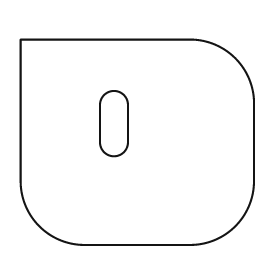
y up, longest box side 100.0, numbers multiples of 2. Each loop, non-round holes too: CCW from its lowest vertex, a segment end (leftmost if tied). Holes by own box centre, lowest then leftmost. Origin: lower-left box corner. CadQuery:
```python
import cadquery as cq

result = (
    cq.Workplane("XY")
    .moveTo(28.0, 0.0)
    .lineTo(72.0, 0.0)
    .threePointArc((92.0, 8.0), (100.0, 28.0))
    .lineTo(100.0, 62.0)
    .threePointArc((92.0, 80.0), (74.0, 88.0))
    .lineTo(0.0, 88.0)
    .lineTo(0.0, 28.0)
    .threePointArc((8.0, 8.0), (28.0, 0.0))
    .close()
    .moveTo(34.0, 44.0)
    .threePointArc((40.0, 38.0), (46.0, 44.0))
    .lineTo(46.0, 60.0)
    .threePointArc((40.0, 66.0), (34.0, 60.0))
    .close()
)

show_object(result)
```